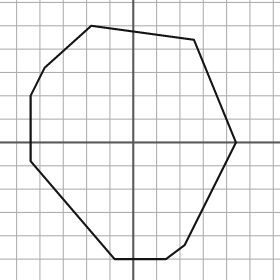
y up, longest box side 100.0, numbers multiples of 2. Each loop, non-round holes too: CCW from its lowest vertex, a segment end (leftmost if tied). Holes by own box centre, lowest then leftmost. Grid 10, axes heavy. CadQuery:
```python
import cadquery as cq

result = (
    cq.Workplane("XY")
    .moveTo(-8.0, -50.0)
    .lineTo(14.0, -50.0)
    .lineTo(22.0, -44.0)
    .lineTo(44.0, 0.0)
    .lineTo(26.0, 44.0)
    .lineTo(-18.0, 50.0)
    .lineTo(-38.0, 32.0)
    .lineTo(-44.0, 20.0)
    .lineTo(-44.0, -8.0)
    .close()
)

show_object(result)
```